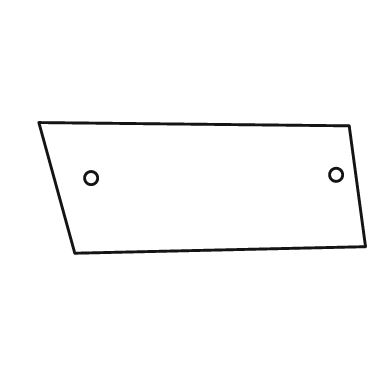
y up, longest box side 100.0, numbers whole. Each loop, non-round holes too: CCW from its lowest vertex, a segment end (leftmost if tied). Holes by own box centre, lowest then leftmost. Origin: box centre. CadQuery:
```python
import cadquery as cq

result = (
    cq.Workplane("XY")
    .moveTo(-39.0, -20.0)
    .lineTo(50.0, -18.0)
    .lineTo(45.0, 19.0)
    .lineTo(-50.0, 20.0)
    .close()
    .moveTo(-34.0, 3.0)
    .circle(2.0)
    .moveTo(41.0, 4.0)
    .circle(2.0)
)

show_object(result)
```